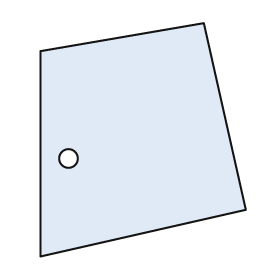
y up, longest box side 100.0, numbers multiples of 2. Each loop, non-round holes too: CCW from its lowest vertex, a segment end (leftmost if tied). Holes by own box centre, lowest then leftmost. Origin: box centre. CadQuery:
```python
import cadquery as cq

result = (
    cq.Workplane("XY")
    .moveTo(-44.0, -50.0)
    .lineTo(44.0, -30.0)
    .lineTo(26.0, 50.0)
    .lineTo(-44.0, 38.0)
    .close()
    .moveTo(-32.0, -8.0)
    .circle(4.0)
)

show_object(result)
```